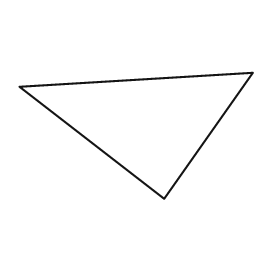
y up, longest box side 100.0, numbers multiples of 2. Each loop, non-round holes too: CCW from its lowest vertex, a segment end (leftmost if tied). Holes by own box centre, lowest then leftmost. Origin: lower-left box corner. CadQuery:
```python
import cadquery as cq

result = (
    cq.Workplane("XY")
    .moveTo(62.0, 0.0)
    .lineTo(100.0, 54.0)
    .lineTo(0.0, 48.0)
    .close()
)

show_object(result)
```